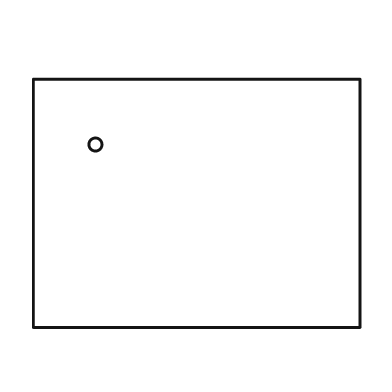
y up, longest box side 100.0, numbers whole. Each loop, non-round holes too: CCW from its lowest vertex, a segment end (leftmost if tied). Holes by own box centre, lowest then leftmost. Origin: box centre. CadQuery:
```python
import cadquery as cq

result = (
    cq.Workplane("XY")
    .moveTo(-50.0, -38.0)
    .lineTo(50.0, -38.0)
    .lineTo(50.0, 38.0)
    .lineTo(-50.0, 38.0)
    .close()
    .moveTo(-31.0, 18.0)
    .circle(2.0)
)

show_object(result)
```